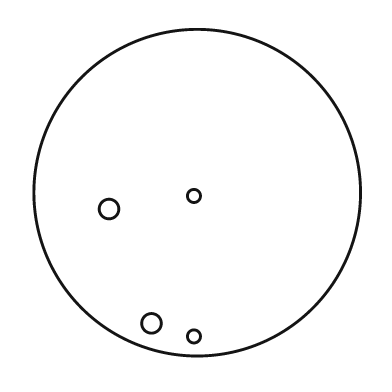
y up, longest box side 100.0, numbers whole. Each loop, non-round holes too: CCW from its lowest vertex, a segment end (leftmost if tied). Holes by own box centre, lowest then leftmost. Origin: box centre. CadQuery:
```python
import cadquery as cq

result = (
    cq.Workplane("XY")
    .moveTo(0.0, 0.0)
    .circle(50.0)
    .moveTo(-1.0, -44.0)
    .circle(2.0)
    .moveTo(-14.0, -40.0)
    .circle(3.0)
    .moveTo(-27.0, -5.0)
    .circle(3.0)
    .moveTo(-1.0, -1.0)
    .circle(2.0)
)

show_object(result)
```